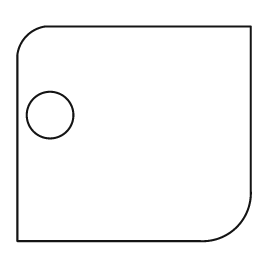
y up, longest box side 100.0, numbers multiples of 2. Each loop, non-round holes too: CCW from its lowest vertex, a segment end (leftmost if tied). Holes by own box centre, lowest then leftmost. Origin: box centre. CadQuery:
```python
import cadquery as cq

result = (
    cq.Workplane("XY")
    .moveTo(-50.0, -46.0)
    .lineTo(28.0, -46.0)
    .threePointArc((44.0, -40.0), (50.0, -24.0))
    .lineTo(50.0, 46.0)
    .lineTo(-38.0, 46.0)
    .threePointArc((-46.0, 42.0), (-50.0, 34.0))
    .close()
    .moveTo(-36.0, 8.0)
    .circle(10.0)
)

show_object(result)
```